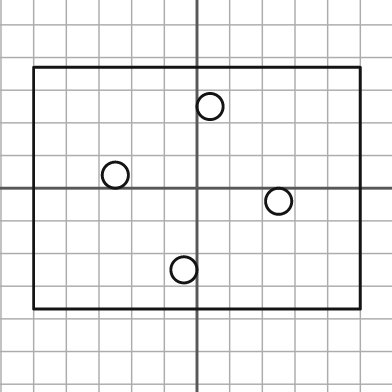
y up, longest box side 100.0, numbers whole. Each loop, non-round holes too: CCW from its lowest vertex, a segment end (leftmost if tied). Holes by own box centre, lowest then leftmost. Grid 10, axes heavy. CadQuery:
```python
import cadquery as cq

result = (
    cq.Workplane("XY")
    .moveTo(-50.0, -37.0)
    .lineTo(50.0, -37.0)
    .lineTo(50.0, 37.0)
    .lineTo(-50.0, 37.0)
    .close()
    .moveTo(-4.0, -25.0)
    .circle(4.0)
    .moveTo(25.0, -4.0)
    .circle(4.0)
    .moveTo(-25.0, 4.0)
    .circle(4.0)
    .moveTo(4.0, 25.0)
    .circle(4.0)
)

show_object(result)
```